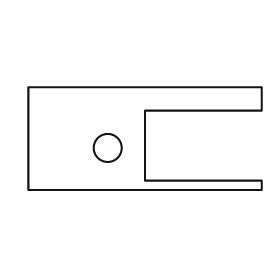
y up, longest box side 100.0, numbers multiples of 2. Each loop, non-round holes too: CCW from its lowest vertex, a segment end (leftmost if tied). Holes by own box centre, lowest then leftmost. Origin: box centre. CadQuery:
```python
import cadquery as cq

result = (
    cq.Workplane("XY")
    .moveTo(-50.0, -22.0)
    .lineTo(50.0, -22.0)
    .lineTo(50.0, -18.0)
    .lineTo(0.0, -18.0)
    .lineTo(0.0, 12.0)
    .lineTo(50.0, 12.0)
    .lineTo(50.0, 22.0)
    .lineTo(-50.0, 22.0)
    .close()
    .moveTo(-16.0, -4.0)
    .circle(6.0)
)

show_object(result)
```